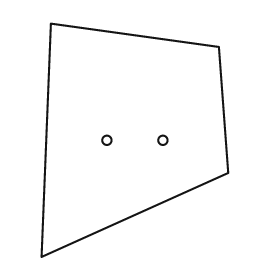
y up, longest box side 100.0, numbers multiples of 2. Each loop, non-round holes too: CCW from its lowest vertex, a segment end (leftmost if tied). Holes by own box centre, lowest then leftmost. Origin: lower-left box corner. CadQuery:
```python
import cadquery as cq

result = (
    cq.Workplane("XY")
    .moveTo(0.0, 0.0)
    .lineTo(80.0, 36.0)
    .lineTo(76.0, 90.0)
    .lineTo(4.0, 100.0)
    .close()
    .moveTo(28.0, 50.0)
    .circle(2.0)
    .moveTo(52.0, 50.0)
    .circle(2.0)
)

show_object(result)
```